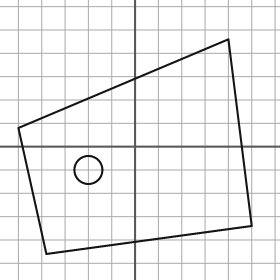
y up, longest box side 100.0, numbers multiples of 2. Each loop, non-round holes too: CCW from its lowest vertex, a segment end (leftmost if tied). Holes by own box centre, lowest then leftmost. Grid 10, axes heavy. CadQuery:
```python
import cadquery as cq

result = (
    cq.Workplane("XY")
    .moveTo(-38.0, -46.0)
    .lineTo(50.0, -34.0)
    .lineTo(40.0, 46.0)
    .lineTo(-50.0, 8.0)
    .close()
    .moveTo(-20.0, -10.0)
    .circle(6.0)
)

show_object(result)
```